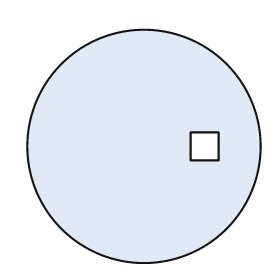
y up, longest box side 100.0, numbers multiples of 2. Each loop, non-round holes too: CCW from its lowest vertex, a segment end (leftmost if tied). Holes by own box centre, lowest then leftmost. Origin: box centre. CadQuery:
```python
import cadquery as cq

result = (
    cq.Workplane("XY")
    .moveTo(0.0, 0.0)
    .circle(50.0)
    .moveTo(20.0, -6.0)
    .lineTo(32.0, -6.0)
    .lineTo(32.0, 6.0)
    .lineTo(20.0, 6.0)
    .close()
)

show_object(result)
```